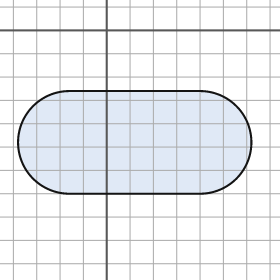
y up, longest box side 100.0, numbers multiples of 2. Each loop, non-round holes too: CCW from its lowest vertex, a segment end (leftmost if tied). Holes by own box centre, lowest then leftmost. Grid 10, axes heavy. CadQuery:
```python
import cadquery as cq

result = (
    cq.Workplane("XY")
    .moveTo(-16.0, -70.0)
    .lineTo(40.0, -70.0)
    .threePointArc((62.0, -48.0), (40.0, -26.0))
    .lineTo(-16.0, -26.0)
    .threePointArc((-38.0, -48.0), (-16.0, -70.0))
    .close()
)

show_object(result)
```